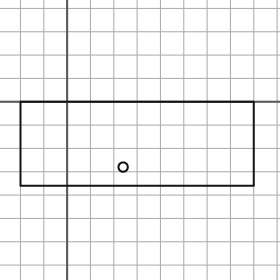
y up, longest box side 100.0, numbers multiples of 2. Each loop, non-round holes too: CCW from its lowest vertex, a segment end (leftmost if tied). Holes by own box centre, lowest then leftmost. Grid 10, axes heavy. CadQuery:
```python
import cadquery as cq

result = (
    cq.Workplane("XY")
    .moveTo(-20.0, -36.0)
    .lineTo(80.0, -36.0)
    .lineTo(80.0, 0.0)
    .lineTo(-20.0, 0.0)
    .close()
    .moveTo(24.0, -28.0)
    .circle(2.0)
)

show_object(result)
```